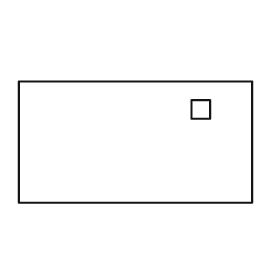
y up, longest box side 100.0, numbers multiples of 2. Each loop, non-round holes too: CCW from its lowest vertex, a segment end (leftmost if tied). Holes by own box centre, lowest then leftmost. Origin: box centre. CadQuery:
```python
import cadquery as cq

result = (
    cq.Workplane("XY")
    .moveTo(-50.0, -26.0)
    .lineTo(50.0, -26.0)
    .lineTo(50.0, 26.0)
    .lineTo(-50.0, 26.0)
    .close()
    .moveTo(24.0, 10.0)
    .lineTo(32.0, 10.0)
    .lineTo(32.0, 18.0)
    .lineTo(24.0, 18.0)
    .close()
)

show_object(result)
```